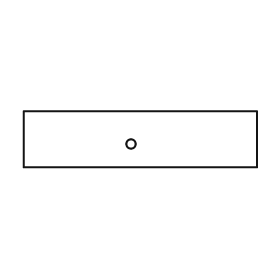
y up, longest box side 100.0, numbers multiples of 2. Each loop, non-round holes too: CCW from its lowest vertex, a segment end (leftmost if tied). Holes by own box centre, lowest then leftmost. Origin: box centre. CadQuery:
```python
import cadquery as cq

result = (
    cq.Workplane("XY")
    .moveTo(-50.0, -12.0)
    .lineTo(50.0, -12.0)
    .lineTo(50.0, 12.0)
    .lineTo(-50.0, 12.0)
    .close()
    .moveTo(-4.0, -2.0)
    .circle(2.0)
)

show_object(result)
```